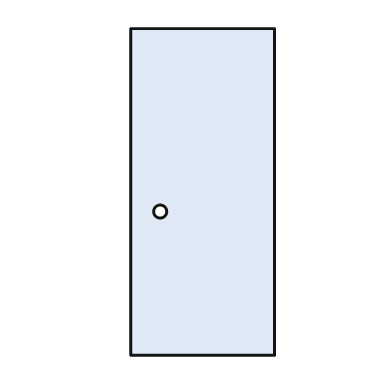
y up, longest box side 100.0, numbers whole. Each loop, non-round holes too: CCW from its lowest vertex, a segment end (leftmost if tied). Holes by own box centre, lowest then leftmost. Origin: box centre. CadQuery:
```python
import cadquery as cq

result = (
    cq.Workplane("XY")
    .moveTo(-22.0, -50.0)
    .lineTo(22.0, -50.0)
    .lineTo(22.0, 50.0)
    .lineTo(-22.0, 50.0)
    .close()
    .moveTo(-13.0, -6.0)
    .circle(2.0)
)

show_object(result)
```